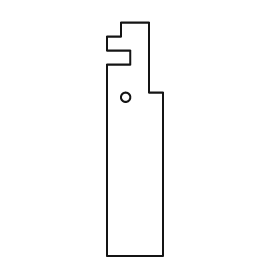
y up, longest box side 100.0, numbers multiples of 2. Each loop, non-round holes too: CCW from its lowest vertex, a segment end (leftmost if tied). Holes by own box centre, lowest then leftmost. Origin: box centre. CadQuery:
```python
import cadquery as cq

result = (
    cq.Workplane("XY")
    .moveTo(-12.0, -50.0)
    .lineTo(12.0, -50.0)
    .lineTo(12.0, 20.0)
    .lineTo(6.0, 20.0)
    .lineTo(6.0, 50.0)
    .lineTo(-6.0, 50.0)
    .lineTo(-6.0, 44.0)
    .lineTo(-12.0, 44.0)
    .lineTo(-12.0, 38.0)
    .lineTo(-2.0, 38.0)
    .lineTo(-2.0, 32.0)
    .lineTo(-12.0, 32.0)
    .close()
    .moveTo(-4.0, 18.0)
    .circle(2.0)
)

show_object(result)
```